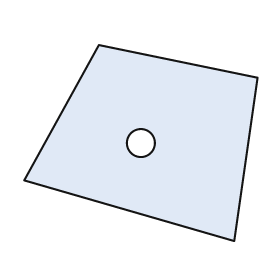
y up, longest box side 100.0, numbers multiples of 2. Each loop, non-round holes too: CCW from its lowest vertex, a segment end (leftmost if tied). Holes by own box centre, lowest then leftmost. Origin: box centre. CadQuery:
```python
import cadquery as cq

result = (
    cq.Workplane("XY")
    .moveTo(40.0, -42.0)
    .lineTo(50.0, 28.0)
    .lineTo(-18.0, 42.0)
    .lineTo(-50.0, -16.0)
    .close()
    .moveTo(0.0, 0.0)
    .circle(6.0)
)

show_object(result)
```